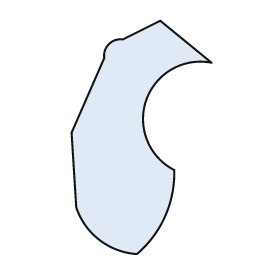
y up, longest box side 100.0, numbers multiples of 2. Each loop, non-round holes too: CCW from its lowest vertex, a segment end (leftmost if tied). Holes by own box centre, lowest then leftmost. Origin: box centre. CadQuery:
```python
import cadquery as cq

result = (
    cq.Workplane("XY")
    .moveTo(-2.0, -50.0)
    .threePointArc((10.0, -34.0), (14.0, -14.0))
    .threePointArc((2.0, 16.0), (30.0, 32.0))
    .lineTo(8.0, 50.0)
    .lineTo(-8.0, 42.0)
    .threePointArc((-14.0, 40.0), (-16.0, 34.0))
    .lineTo(-30.0, 2.0)
    .lineTo(-28.0, -30.0)
    .threePointArc((-18.0, -44.0), (-2.0, -50.0))
    .close()
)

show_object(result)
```